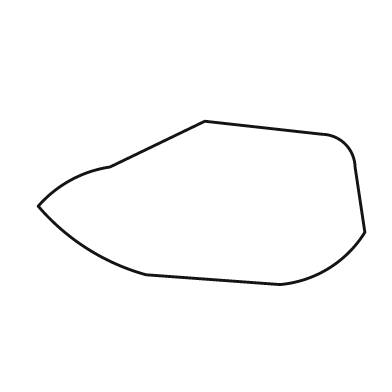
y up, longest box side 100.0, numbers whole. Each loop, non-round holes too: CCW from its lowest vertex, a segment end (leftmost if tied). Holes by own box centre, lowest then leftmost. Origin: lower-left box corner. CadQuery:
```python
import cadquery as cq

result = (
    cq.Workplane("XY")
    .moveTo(74.0, 0.0)
    .threePointArc((89.0, 5.0), (100.0, 16.0))
    .lineTo(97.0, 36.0)
    .threePointArc((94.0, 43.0), (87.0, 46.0))
    .lineTo(51.0, 50.0)
    .lineTo(22.0, 36.0)
    .threePointArc((10.0, 32.0), (0.0, 24.0))
    .threePointArc((15.0, 11.0), (33.0, 3.0))
    .close()
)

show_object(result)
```